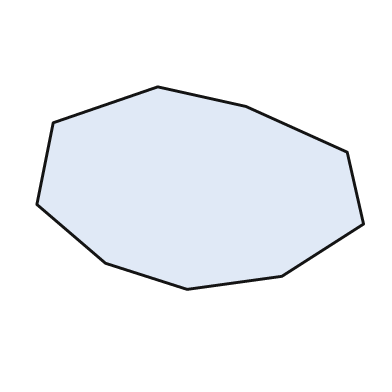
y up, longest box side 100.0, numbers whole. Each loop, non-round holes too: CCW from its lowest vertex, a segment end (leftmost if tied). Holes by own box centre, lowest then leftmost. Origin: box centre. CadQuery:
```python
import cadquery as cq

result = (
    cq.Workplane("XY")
    .moveTo(-4.0, -31.0)
    .lineTo(25.0, -27.0)
    .lineTo(50.0, -11.0)
    .lineTo(45.0, 11.0)
    .lineTo(14.0, 25.0)
    .lineTo(-13.0, 31.0)
    .lineTo(-45.0, 20.0)
    .lineTo(-50.0, -5.0)
    .lineTo(-29.0, -23.0)
    .close()
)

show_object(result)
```